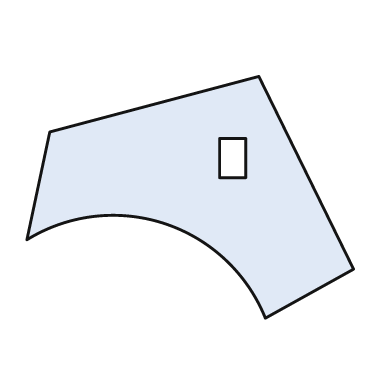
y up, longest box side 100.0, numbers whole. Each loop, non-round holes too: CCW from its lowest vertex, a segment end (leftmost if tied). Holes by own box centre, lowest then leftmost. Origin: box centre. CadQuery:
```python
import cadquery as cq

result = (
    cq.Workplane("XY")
    .moveTo(23.0, -37.0)
    .lineTo(50.0, -22.0)
    .lineTo(21.0, 37.0)
    .lineTo(-43.0, 20.0)
    .lineTo(-50.0, -13.0)
    .threePointArc((-8.0, -8.0), (23.0, -37.0))
    .close()
    .moveTo(9.0, 6.0)
    .lineTo(17.0, 6.0)
    .lineTo(17.0, 18.0)
    .lineTo(9.0, 18.0)
    .close()
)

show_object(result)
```